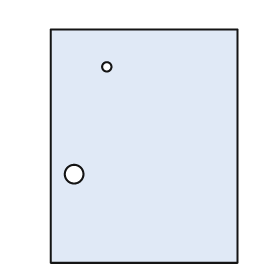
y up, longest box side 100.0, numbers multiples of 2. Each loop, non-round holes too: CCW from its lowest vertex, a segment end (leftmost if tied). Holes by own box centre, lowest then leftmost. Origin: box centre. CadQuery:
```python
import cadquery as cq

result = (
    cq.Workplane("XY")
    .moveTo(-40.0, -50.0)
    .lineTo(40.0, -50.0)
    .lineTo(40.0, 50.0)
    .lineTo(-40.0, 50.0)
    .close()
    .moveTo(-30.0, -12.0)
    .circle(4.0)
    .moveTo(-16.0, 34.0)
    .circle(2.0)
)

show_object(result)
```